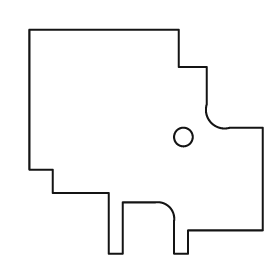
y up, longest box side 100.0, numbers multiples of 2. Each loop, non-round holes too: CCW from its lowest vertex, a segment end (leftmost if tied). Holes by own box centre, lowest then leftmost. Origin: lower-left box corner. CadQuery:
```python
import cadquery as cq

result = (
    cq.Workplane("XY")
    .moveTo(34.0, 0.0)
    .lineTo(40.0, 0.0)
    .lineTo(40.0, 22.0)
    .lineTo(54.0, 22.0)
    .threePointArc((60.0, 20.0), (62.0, 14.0))
    .lineTo(62.0, 0.0)
    .lineTo(68.0, 0.0)
    .lineTo(68.0, 10.0)
    .lineTo(100.0, 10.0)
    .lineTo(100.0, 54.0)
    .lineTo(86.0, 54.0)
    .threePointArc((78.0, 56.0), (76.0, 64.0))
    .lineTo(76.0, 80.0)
    .lineTo(64.0, 80.0)
    .lineTo(64.0, 96.0)
    .lineTo(0.0, 96.0)
    .lineTo(0.0, 36.0)
    .lineTo(10.0, 36.0)
    .lineTo(10.0, 26.0)
    .lineTo(34.0, 26.0)
    .close()
    .moveTo(66.0, 50.0)
    .circle(4.0)
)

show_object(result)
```